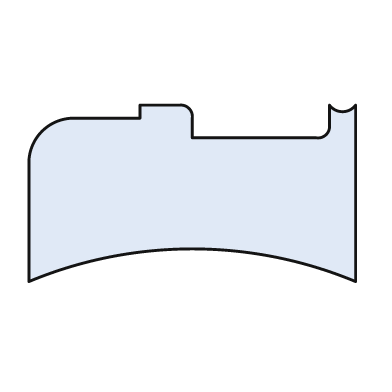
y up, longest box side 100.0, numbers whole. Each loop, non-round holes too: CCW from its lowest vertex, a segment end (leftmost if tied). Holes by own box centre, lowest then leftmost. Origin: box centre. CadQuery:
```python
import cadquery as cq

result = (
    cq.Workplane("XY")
    .moveTo(-50.0, -27.0)
    .threePointArc((0.0, -17.0), (50.0, -27.0))
    .lineTo(50.0, 27.0)
    .threePointArc((46.0, 25.0), (42.0, 27.0))
    .lineTo(42.0, 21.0)
    .threePointArc((41.0, 18.0), (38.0, 17.0))
    .lineTo(0.0, 17.0)
    .lineTo(0.0, 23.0)
    .threePointArc((-1.0, 26.0), (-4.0, 27.0))
    .lineTo(-16.0, 27.0)
    .lineTo(-16.0, 23.0)
    .lineTo(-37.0, 23.0)
    .threePointArc((-46.0, 19.0), (-50.0, 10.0))
    .close()
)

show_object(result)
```